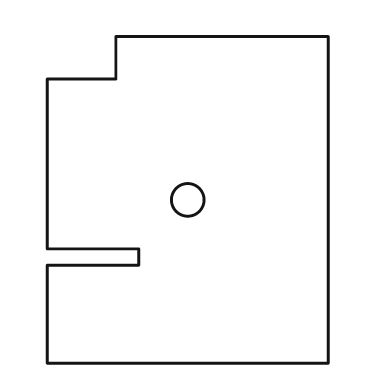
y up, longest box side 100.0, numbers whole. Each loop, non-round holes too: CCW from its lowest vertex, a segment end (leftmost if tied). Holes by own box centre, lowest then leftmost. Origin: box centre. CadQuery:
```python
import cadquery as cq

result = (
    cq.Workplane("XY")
    .moveTo(-43.0, -50.0)
    .lineTo(43.0, -50.0)
    .lineTo(43.0, 50.0)
    .lineTo(-22.0, 50.0)
    .lineTo(-22.0, 37.0)
    .lineTo(-43.0, 37.0)
    .lineTo(-43.0, -15.0)
    .lineTo(-15.0, -15.0)
    .lineTo(-15.0, -20.0)
    .lineTo(-43.0, -20.0)
    .close()
    .moveTo(0.0, 0.0)
    .circle(5.0)
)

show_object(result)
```